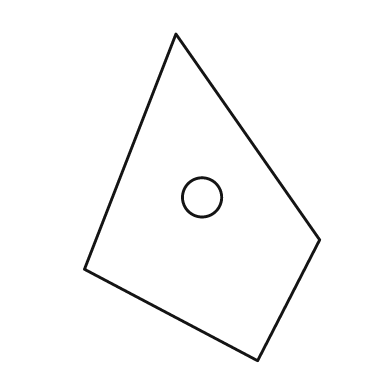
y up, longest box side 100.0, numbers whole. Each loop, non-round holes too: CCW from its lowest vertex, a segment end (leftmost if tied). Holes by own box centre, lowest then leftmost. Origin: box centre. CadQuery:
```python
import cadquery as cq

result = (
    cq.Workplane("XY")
    .moveTo(17.0, -50.0)
    .lineTo(36.0, -13.0)
    .lineTo(-8.0, 50.0)
    .lineTo(-36.0, -22.0)
    .close()
    .moveTo(0.0, 0.0)
    .circle(6.0)
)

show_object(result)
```